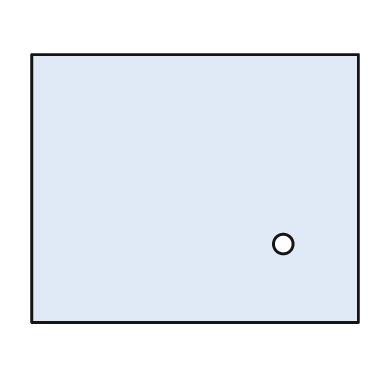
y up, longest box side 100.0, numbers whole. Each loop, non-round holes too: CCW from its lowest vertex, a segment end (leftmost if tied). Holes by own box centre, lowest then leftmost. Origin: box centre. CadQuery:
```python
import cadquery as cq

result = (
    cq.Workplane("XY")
    .moveTo(-50.0, -41.0)
    .lineTo(50.0, -41.0)
    .lineTo(50.0, 41.0)
    .lineTo(-50.0, 41.0)
    .close()
    .moveTo(27.0, -17.0)
    .circle(3.0)
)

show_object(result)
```